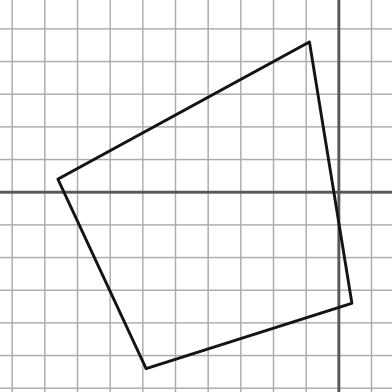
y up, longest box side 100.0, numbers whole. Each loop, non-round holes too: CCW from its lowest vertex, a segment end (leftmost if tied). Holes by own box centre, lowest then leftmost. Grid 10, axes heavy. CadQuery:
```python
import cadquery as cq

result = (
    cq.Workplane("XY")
    .moveTo(-59.0, -54.0)
    .lineTo(4.0, -34.0)
    .lineTo(-9.0, 46.0)
    .lineTo(-86.0, 4.0)
    .close()
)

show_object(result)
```